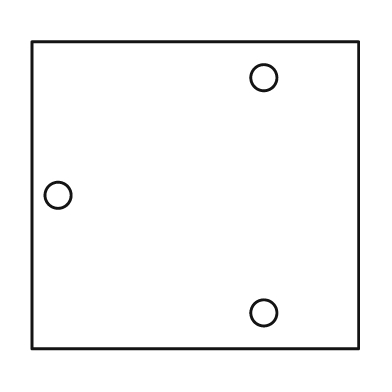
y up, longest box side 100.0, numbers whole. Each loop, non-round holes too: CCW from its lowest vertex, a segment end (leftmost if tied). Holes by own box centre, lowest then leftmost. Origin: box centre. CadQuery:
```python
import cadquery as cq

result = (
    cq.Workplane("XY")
    .moveTo(-50.0, -47.0)
    .lineTo(50.0, -47.0)
    .lineTo(50.0, 47.0)
    .lineTo(-50.0, 47.0)
    .close()
    .moveTo(21.0, -36.0)
    .circle(4.0)
    .moveTo(-42.0, 0.0)
    .circle(4.0)
    .moveTo(21.0, 36.0)
    .circle(4.0)
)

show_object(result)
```